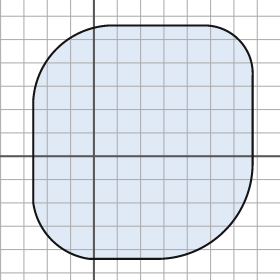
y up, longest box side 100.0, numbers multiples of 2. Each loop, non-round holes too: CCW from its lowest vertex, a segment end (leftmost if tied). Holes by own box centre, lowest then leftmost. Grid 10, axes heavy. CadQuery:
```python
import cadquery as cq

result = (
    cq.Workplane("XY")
    .moveTo(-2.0, -44.0)
    .lineTo(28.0, -44.0)
    .threePointArc((56.0, -32.0), (68.0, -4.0))
    .lineTo(68.0, 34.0)
    .threePointArc((62.0, 50.0), (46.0, 56.0))
    .lineTo(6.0, 56.0)
    .threePointArc((-16.0, 46.0), (-26.0, 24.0))
    .lineTo(-26.0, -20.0)
    .threePointArc((-18.0, -36.0), (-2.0, -44.0))
    .close()
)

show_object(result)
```